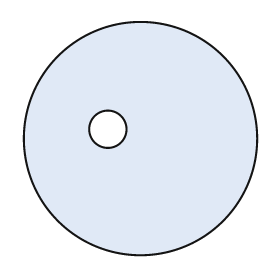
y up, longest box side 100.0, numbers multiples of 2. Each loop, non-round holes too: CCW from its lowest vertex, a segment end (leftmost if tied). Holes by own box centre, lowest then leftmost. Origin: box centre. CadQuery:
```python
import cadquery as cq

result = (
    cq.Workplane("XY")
    .moveTo(0.0, 0.0)
    .circle(50.0)
    .moveTo(-14.0, 4.0)
    .circle(8.0)
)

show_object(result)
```